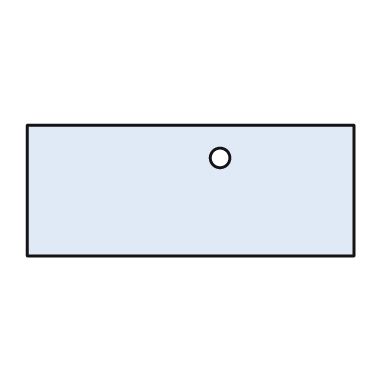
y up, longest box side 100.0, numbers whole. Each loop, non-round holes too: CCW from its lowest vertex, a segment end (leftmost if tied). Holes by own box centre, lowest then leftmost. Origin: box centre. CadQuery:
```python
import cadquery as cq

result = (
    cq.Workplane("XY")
    .moveTo(-50.0, -20.0)
    .lineTo(50.0, -20.0)
    .lineTo(50.0, 20.0)
    .lineTo(-50.0, 20.0)
    .close()
    .moveTo(9.0, 10.0)
    .circle(3.0)
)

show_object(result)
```